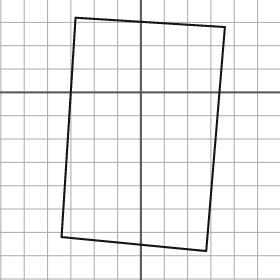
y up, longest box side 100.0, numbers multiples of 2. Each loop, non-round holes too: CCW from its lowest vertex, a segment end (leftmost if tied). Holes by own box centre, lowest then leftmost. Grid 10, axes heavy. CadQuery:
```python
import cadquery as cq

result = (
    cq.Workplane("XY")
    .moveTo(28.0, -68.0)
    .lineTo(36.0, 28.0)
    .lineTo(-28.0, 32.0)
    .lineTo(-34.0, -62.0)
    .close()
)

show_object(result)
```